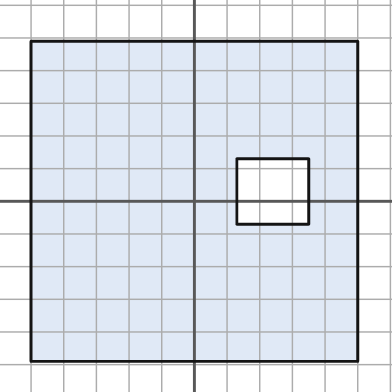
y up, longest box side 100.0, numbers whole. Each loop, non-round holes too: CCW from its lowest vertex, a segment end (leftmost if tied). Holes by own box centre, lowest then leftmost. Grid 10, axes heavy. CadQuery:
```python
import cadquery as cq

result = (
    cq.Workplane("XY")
    .moveTo(-50.0, -49.0)
    .lineTo(50.0, -49.0)
    .lineTo(50.0, 49.0)
    .lineTo(-50.0, 49.0)
    .close()
    .moveTo(13.0, -7.0)
    .lineTo(35.0, -7.0)
    .lineTo(35.0, 13.0)
    .lineTo(13.0, 13.0)
    .close()
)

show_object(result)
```